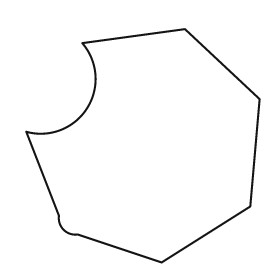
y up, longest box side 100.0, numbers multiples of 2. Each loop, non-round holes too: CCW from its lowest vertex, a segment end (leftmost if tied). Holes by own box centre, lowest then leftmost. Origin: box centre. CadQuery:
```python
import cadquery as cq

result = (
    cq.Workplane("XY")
    .moveTo(8.0, -50.0)
    .lineTo(46.0, -26.0)
    .lineTo(50.0, 20.0)
    .lineTo(18.0, 50.0)
    .lineTo(-26.0, 44.0)
    .threePointArc((-24.0, 16.0), (-50.0, 6.0))
    .lineTo(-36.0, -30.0)
    .threePointArc((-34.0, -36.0), (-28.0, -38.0))
    .close()
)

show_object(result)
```